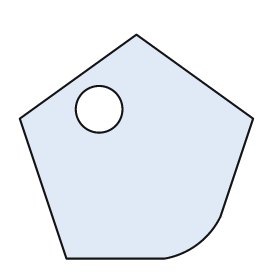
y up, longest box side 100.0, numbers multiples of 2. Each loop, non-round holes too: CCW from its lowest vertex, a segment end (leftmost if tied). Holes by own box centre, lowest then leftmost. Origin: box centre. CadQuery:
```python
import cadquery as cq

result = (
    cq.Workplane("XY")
    .moveTo(-30.0, -48.0)
    .lineTo(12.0, -48.0)
    .threePointArc((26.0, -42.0), (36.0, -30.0))
    .lineTo(50.0, 12.0)
    .lineTo(0.0, 48.0)
    .lineTo(-50.0, 12.0)
    .close()
    .moveTo(-16.0, 16.0)
    .circle(10.0)
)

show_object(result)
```